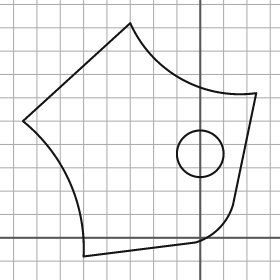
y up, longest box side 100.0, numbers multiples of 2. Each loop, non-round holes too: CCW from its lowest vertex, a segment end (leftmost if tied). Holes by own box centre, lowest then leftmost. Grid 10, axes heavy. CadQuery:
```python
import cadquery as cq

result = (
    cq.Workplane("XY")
    .moveTo(-50.0, -8.0)
    .lineTo(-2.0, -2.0)
    .threePointArc((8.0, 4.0), (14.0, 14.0))
    .lineTo(24.0, 62.0)
    .threePointArc((-8.0, 68.0), (-30.0, 92.0))
    .lineTo(-76.0, 50.0)
    .threePointArc((-56.0, 24.0), (-50.0, -8.0))
    .close()
    .moveTo(0.0, 36.0)
    .circle(10.0)
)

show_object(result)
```